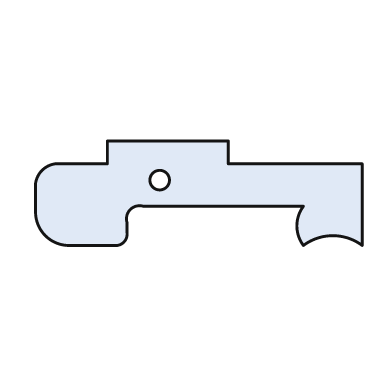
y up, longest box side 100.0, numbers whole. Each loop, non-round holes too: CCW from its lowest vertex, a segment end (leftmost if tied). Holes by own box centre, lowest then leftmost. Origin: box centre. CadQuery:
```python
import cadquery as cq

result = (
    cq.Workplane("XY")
    .moveTo(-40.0, -16.0)
    .lineTo(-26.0, -16.0)
    .threePointArc((-23.0, -15.0), (-22.0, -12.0))
    .lineTo(-22.0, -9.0)
    .threePointArc((-21.0, -5.0), (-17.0, -4.0))
    .lineTo(32.0, -4.0)
    .threePointArc((30.0, -10.0), (32.0, -16.0))
    .threePointArc((41.0, -13.0), (50.0, -16.0))
    .lineTo(50.0, 9.0)
    .lineTo(9.0, 9.0)
    .lineTo(9.0, 16.0)
    .lineTo(-28.0, 16.0)
    .lineTo(-28.0, 9.0)
    .lineTo(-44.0, 9.0)
    .threePointArc((-48.0, 7.0), (-50.0, 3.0))
    .lineTo(-50.0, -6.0)
    .threePointArc((-47.0, -13.0), (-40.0, -16.0))
    .close()
    .moveTo(-12.0, 4.0)
    .circle(3.0)
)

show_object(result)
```